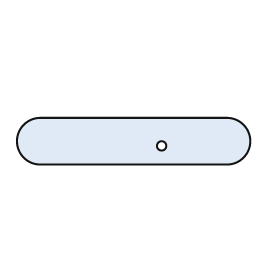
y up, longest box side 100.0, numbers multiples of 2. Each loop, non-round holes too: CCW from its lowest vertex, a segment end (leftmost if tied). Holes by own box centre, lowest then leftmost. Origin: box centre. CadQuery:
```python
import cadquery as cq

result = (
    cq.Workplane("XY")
    .moveTo(-40.0, -10.0)
    .lineTo(40.0, -10.0)
    .threePointArc((50.0, 0.0), (40.0, 10.0))
    .lineTo(-40.0, 10.0)
    .threePointArc((-50.0, 0.0), (-40.0, -10.0))
    .close()
    .moveTo(12.0, -2.0)
    .circle(2.0)
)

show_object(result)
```